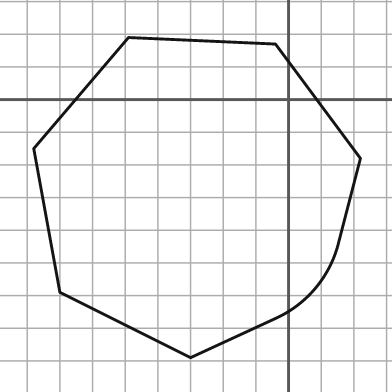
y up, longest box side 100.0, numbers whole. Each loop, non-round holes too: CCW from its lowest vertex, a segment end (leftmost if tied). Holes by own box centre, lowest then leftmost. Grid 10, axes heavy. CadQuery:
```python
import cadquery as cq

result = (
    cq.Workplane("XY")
    .moveTo(-30.0, -79.0)
    .lineTo(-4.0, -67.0)
    .threePointArc((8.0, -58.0), (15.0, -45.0))
    .lineTo(22.0, -18.0)
    .lineTo(-4.0, 17.0)
    .lineTo(-49.0, 19.0)
    .lineTo(-78.0, -15.0)
    .lineTo(-70.0, -59.0)
    .close()
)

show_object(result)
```